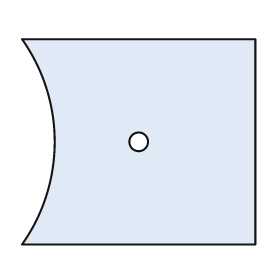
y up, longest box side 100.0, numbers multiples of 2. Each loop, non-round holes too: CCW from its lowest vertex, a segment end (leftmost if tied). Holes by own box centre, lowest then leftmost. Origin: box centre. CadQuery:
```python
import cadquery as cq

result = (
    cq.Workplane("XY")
    .moveTo(-50.0, -44.0)
    .lineTo(50.0, -44.0)
    .lineTo(50.0, 44.0)
    .lineTo(-50.0, 44.0)
    .threePointArc((-36.0, 0.0), (-50.0, -44.0))
    .close()
    .moveTo(0.0, 0.0)
    .circle(4.0)
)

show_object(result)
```